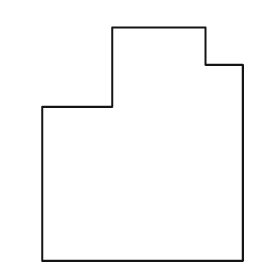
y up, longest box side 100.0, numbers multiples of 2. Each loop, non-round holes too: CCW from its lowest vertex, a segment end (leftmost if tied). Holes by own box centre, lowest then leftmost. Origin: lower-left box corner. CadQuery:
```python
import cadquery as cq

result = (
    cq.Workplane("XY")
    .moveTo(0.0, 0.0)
    .lineTo(86.0, 0.0)
    .lineTo(86.0, 84.0)
    .lineTo(70.0, 84.0)
    .lineTo(70.0, 100.0)
    .lineTo(30.0, 100.0)
    .lineTo(30.0, 66.0)
    .lineTo(0.0, 66.0)
    .close()
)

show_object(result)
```